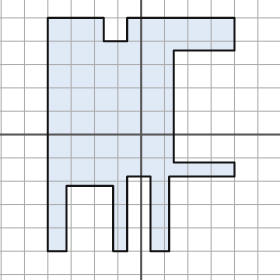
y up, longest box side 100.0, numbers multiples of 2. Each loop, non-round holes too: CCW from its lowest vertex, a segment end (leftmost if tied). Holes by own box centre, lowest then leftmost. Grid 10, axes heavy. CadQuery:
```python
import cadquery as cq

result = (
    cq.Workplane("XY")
    .moveTo(-40.0, -50.0)
    .lineTo(-32.0, -50.0)
    .lineTo(-32.0, -22.0)
    .lineTo(-12.0, -22.0)
    .lineTo(-12.0, -50.0)
    .lineTo(-6.0, -50.0)
    .lineTo(-6.0, -18.0)
    .lineTo(4.0, -18.0)
    .lineTo(4.0, -50.0)
    .lineTo(12.0, -50.0)
    .lineTo(12.0, -18.0)
    .lineTo(40.0, -18.0)
    .lineTo(40.0, -12.0)
    .lineTo(14.0, -12.0)
    .lineTo(14.0, 36.0)
    .lineTo(40.0, 36.0)
    .lineTo(40.0, 50.0)
    .lineTo(-6.0, 50.0)
    .lineTo(-6.0, 40.0)
    .lineTo(-16.0, 40.0)
    .lineTo(-16.0, 50.0)
    .lineTo(-40.0, 50.0)
    .close()
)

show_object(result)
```